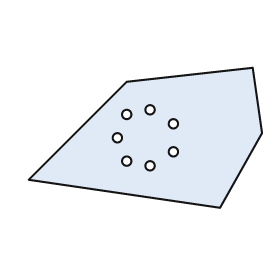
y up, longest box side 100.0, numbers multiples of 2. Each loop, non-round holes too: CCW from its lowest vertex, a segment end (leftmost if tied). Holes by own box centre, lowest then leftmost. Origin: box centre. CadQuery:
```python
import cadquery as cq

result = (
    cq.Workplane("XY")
    .moveTo(32.0, -30.0)
    .lineTo(50.0, 2.0)
    .lineTo(46.0, 30.0)
    .lineTo(-8.0, 24.0)
    .lineTo(-50.0, -18.0)
    .close()
    .moveTo(2.0, -12.0)
    .circle(2.0)
    .moveTo(-8.0, -10.0)
    .circle(2.0)
    .moveTo(12.0, -6.0)
    .circle(2.0)
    .moveTo(-12.0, 0.0)
    .circle(2.0)
    .moveTo(12.0, 6.0)
    .circle(2.0)
    .moveTo(-8.0, 10.0)
    .circle(2.0)
    .moveTo(2.0, 12.0)
    .circle(2.0)
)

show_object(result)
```